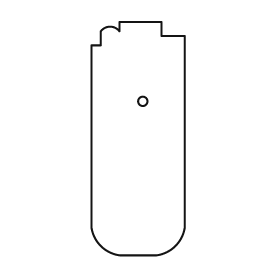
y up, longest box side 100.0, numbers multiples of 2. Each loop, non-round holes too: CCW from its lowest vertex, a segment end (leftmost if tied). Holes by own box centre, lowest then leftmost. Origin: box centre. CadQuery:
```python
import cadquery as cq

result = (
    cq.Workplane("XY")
    .moveTo(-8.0, -50.0)
    .lineTo(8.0, -50.0)
    .threePointArc((16.0, -46.0), (20.0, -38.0))
    .lineTo(20.0, 44.0)
    .lineTo(10.0, 44.0)
    .lineTo(10.0, 50.0)
    .lineTo(-8.0, 50.0)
    .lineTo(-8.0, 46.0)
    .threePointArc((-12.0, 48.0), (-16.0, 46.0))
    .lineTo(-16.0, 40.0)
    .lineTo(-20.0, 40.0)
    .lineTo(-20.0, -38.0)
    .threePointArc((-16.0, -46.0), (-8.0, -50.0))
    .close()
    .moveTo(2.0, 16.0)
    .circle(2.0)
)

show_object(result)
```